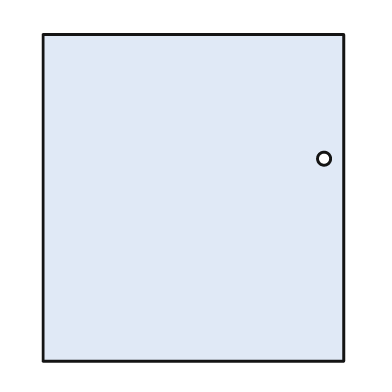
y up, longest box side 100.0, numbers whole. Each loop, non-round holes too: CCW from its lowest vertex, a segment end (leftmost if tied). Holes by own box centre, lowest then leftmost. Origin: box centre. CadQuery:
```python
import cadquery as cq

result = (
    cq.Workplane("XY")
    .moveTo(-46.0, -50.0)
    .lineTo(46.0, -50.0)
    .lineTo(46.0, 50.0)
    .lineTo(-46.0, 50.0)
    .close()
    .moveTo(40.0, 12.0)
    .circle(2.0)
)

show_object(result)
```